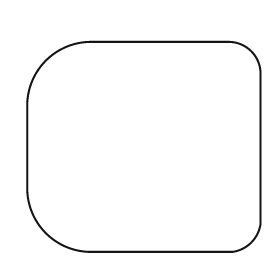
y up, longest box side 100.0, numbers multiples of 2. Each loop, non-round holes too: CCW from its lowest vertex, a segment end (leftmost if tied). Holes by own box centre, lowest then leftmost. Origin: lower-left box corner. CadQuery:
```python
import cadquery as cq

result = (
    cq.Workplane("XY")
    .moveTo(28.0, 0.0)
    .lineTo(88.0, 0.0)
    .threePointArc((96.0, 4.0), (100.0, 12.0))
    .lineTo(100.0, 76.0)
    .threePointArc((96.0, 86.0), (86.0, 90.0))
    .lineTo(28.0, 90.0)
    .threePointArc((8.0, 82.0), (0.0, 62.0))
    .lineTo(0.0, 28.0)
    .threePointArc((8.0, 8.0), (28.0, 0.0))
    .close()
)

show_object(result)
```